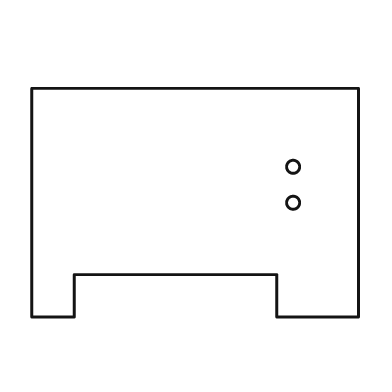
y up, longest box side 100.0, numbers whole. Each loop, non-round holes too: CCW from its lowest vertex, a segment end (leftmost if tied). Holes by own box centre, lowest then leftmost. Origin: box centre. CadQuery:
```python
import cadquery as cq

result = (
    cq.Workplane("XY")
    .moveTo(-50.0, -35.0)
    .lineTo(-37.0, -35.0)
    .lineTo(-37.0, -22.0)
    .lineTo(25.0, -22.0)
    .lineTo(25.0, -35.0)
    .lineTo(50.0, -35.0)
    .lineTo(50.0, 35.0)
    .lineTo(-50.0, 35.0)
    .close()
    .moveTo(30.0, 0.0)
    .circle(2.0)
    .moveTo(30.0, 11.0)
    .circle(2.0)
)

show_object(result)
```